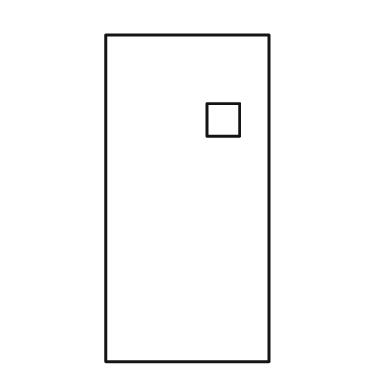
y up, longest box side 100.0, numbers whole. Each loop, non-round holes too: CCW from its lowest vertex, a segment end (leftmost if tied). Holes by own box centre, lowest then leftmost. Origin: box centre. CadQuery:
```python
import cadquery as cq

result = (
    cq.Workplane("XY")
    .moveTo(-25.0, -50.0)
    .lineTo(25.0, -50.0)
    .lineTo(25.0, 50.0)
    .lineTo(-25.0, 50.0)
    .close()
    .moveTo(6.0, 19.0)
    .lineTo(16.0, 19.0)
    .lineTo(16.0, 29.0)
    .lineTo(6.0, 29.0)
    .close()
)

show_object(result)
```